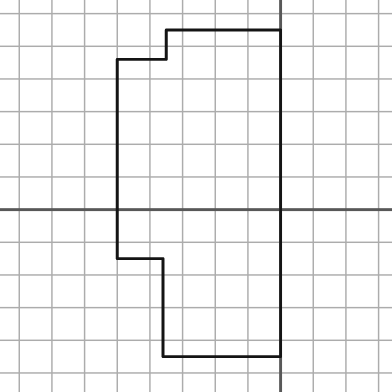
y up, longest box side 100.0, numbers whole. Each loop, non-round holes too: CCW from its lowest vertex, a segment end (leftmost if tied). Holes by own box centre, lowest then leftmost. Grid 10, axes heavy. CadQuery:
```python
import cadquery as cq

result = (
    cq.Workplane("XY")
    .moveTo(-36.0, -45.0)
    .lineTo(0.0, -45.0)
    .lineTo(0.0, 55.0)
    .lineTo(-35.0, 55.0)
    .lineTo(-35.0, 46.0)
    .lineTo(-50.0, 46.0)
    .lineTo(-50.0, -15.0)
    .lineTo(-36.0, -15.0)
    .close()
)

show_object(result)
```